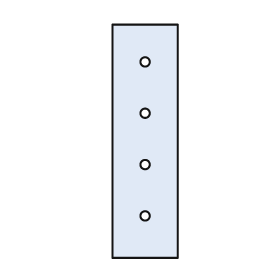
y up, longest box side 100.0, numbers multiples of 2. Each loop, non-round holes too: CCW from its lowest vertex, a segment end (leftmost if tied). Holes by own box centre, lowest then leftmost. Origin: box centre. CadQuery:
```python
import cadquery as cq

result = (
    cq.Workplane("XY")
    .moveTo(-14.0, -50.0)
    .lineTo(14.0, -50.0)
    .lineTo(14.0, 50.0)
    .lineTo(-14.0, 50.0)
    .close()
    .moveTo(0.0, -32.0)
    .circle(2.0)
    .moveTo(0.0, -10.0)
    .circle(2.0)
    .moveTo(0.0, 12.0)
    .circle(2.0)
    .moveTo(0.0, 34.0)
    .circle(2.0)
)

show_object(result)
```